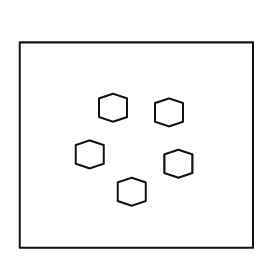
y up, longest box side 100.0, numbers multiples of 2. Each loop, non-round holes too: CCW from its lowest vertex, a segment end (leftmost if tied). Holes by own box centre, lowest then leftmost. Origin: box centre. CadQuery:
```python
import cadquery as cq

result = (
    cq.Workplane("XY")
    .moveTo(-50.0, -44.0)
    .lineTo(50.0, -44.0)
    .lineTo(50.0, 44.0)
    .lineTo(-50.0, 44.0)
    .close()
    .moveTo(-2.0, -26.0)
    .lineTo(4.0, -24.0)
    .lineTo(4.0, -16.0)
    .lineTo(-2.0, -14.0)
    .lineTo(-8.0, -16.0)
    .lineTo(-8.0, -24.0)
    .close()
    .moveTo(18.0, -14.0)
    .lineTo(24.0, -12.0)
    .lineTo(24.0, -4.0)
    .lineTo(18.0, -2.0)
    .lineTo(12.0, -4.0)
    .lineTo(12.0, -12.0)
    .close()
    .moveTo(-20.0, -10.0)
    .lineTo(-14.0, -8.0)
    .lineTo(-14.0, 0.0)
    .lineTo(-20.0, 2.0)
    .lineTo(-26.0, 0.0)
    .lineTo(-26.0, -8.0)
    .close()
    .moveTo(14.0, 8.0)
    .lineTo(20.0, 10.0)
    .lineTo(20.0, 18.0)
    .lineTo(14.0, 20.0)
    .lineTo(8.0, 18.0)
    .lineTo(8.0, 10.0)
    .close()
    .moveTo(-10.0, 10.0)
    .lineTo(-4.0, 12.0)
    .lineTo(-4.0, 20.0)
    .lineTo(-10.0, 22.0)
    .lineTo(-16.0, 20.0)
    .lineTo(-16.0, 12.0)
    .close()
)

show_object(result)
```